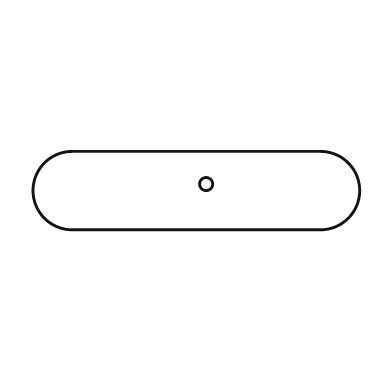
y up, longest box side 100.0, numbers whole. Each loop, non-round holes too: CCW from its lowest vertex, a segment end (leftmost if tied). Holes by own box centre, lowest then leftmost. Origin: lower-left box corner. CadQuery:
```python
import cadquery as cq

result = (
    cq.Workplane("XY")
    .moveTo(12.0, 0.0)
    .lineTo(88.0, 0.0)
    .threePointArc((100.0, 12.0), (88.0, 24.0))
    .lineTo(12.0, 24.0)
    .threePointArc((0.0, 12.0), (12.0, 0.0))
    .close()
    .moveTo(53.0, 14.0)
    .circle(2.0)
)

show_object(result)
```